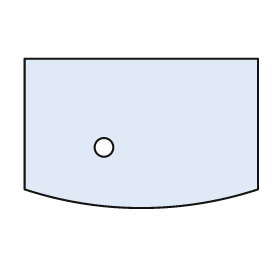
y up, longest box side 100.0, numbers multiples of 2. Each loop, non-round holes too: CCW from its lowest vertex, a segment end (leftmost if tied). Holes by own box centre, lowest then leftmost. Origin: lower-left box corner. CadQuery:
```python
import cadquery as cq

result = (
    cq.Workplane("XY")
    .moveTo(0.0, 8.0)
    .threePointArc((50.0, 0.0), (100.0, 8.0))
    .lineTo(100.0, 64.0)
    .lineTo(0.0, 64.0)
    .close()
    .moveTo(34.0, 26.0)
    .circle(4.0)
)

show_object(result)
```